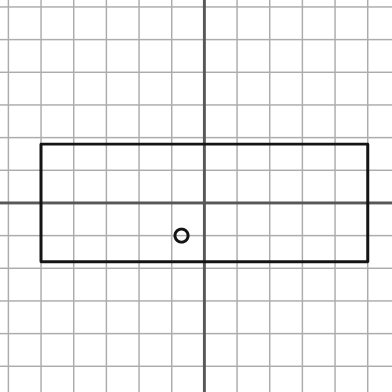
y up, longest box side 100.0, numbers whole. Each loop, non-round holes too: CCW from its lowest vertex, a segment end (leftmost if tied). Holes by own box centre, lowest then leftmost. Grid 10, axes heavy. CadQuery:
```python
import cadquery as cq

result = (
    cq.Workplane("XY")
    .moveTo(-50.0, -18.0)
    .lineTo(50.0, -18.0)
    .lineTo(50.0, 18.0)
    .lineTo(-50.0, 18.0)
    .close()
    .moveTo(-7.0, -10.0)
    .circle(2.0)
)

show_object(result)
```